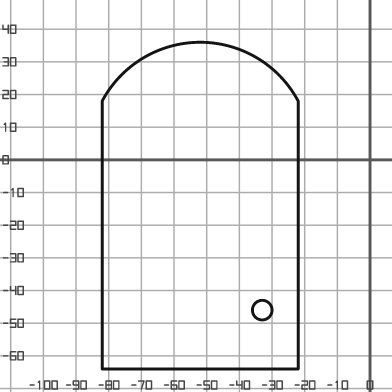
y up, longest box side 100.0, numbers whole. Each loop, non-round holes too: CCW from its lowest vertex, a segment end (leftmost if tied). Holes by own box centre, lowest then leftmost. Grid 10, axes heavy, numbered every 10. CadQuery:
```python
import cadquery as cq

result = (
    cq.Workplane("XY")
    .moveTo(-82.0, -64.0)
    .lineTo(-22.0, -64.0)
    .lineTo(-22.0, 18.0)
    .threePointArc((-52.0, 36.0), (-82.0, 18.0))
    .close()
    .moveTo(-33.0, -46.0)
    .circle(3.0)
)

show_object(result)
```